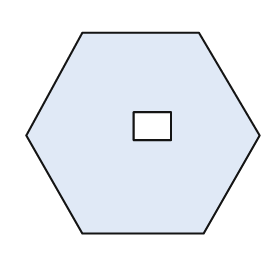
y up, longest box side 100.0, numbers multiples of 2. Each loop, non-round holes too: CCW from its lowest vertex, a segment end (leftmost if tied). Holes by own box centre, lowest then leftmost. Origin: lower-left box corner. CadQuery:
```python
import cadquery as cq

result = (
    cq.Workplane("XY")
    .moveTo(24.0, 0.0)
    .lineTo(76.0, 0.0)
    .lineTo(100.0, 42.0)
    .lineTo(74.0, 86.0)
    .lineTo(24.0, 86.0)
    .lineTo(0.0, 42.0)
    .close()
    .moveTo(46.0, 40.0)
    .lineTo(62.0, 40.0)
    .lineTo(62.0, 52.0)
    .lineTo(46.0, 52.0)
    .close()
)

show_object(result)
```